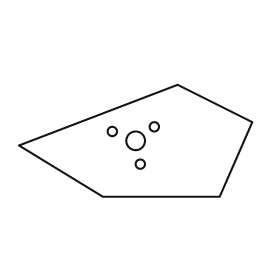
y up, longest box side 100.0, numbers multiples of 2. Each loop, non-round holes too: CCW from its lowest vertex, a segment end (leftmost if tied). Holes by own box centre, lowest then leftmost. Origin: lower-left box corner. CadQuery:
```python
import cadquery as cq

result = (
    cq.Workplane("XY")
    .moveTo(36.0, 0.0)
    .lineTo(86.0, 0.0)
    .lineTo(100.0, 32.0)
    .lineTo(68.0, 48.0)
    .lineTo(0.0, 22.0)
    .close()
    .moveTo(52.0, 14.0)
    .circle(2.0)
    .moveTo(50.0, 24.0)
    .circle(4.0)
    .moveTo(40.0, 28.0)
    .circle(2.0)
    .moveTo(58.0, 30.0)
    .circle(2.0)
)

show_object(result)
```